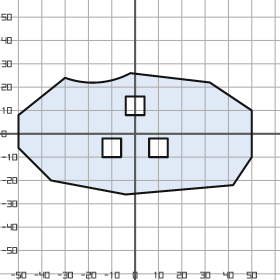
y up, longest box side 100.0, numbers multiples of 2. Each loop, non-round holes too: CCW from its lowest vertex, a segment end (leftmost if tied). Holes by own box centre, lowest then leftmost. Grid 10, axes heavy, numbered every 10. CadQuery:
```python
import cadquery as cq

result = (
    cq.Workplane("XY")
    .moveTo(-4.0, -26.0)
    .lineTo(42.0, -22.0)
    .lineTo(50.0, -10.0)
    .lineTo(50.0, 10.0)
    .lineTo(32.0, 22.0)
    .lineTo(-2.0, 26.0)
    .threePointArc((-16.0, 22.0), (-30.0, 24.0))
    .lineTo(-50.0, 8.0)
    .lineTo(-50.0, -6.0)
    .lineTo(-36.0, -20.0)
    .close()
    .moveTo(-14.0, -10.0)
    .lineTo(-6.0, -10.0)
    .lineTo(-6.0, -2.0)
    .lineTo(-14.0, -2.0)
    .close()
    .moveTo(6.0, -10.0)
    .lineTo(14.0, -10.0)
    .lineTo(14.0, -2.0)
    .lineTo(6.0, -2.0)
    .close()
    .moveTo(-4.0, 8.0)
    .lineTo(4.0, 8.0)
    .lineTo(4.0, 16.0)
    .lineTo(-4.0, 16.0)
    .close()
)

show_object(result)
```